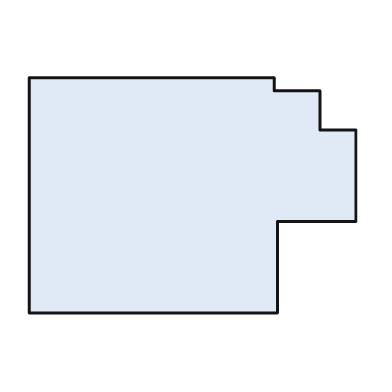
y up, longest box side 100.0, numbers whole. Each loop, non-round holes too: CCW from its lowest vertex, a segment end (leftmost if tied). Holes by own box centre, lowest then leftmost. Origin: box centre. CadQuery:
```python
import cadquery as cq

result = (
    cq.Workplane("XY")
    .moveTo(-50.0, -36.0)
    .lineTo(26.0, -36.0)
    .lineTo(26.0, -8.0)
    .lineTo(50.0, -8.0)
    .lineTo(50.0, 20.0)
    .lineTo(39.0, 20.0)
    .lineTo(39.0, 32.0)
    .lineTo(25.0, 32.0)
    .lineTo(25.0, 36.0)
    .lineTo(-50.0, 36.0)
    .close()
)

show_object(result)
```